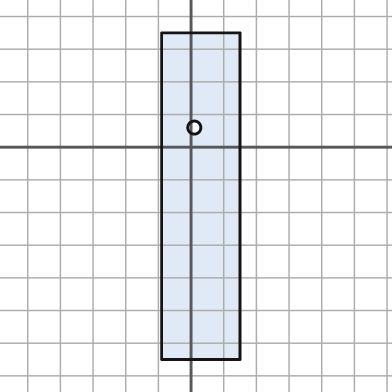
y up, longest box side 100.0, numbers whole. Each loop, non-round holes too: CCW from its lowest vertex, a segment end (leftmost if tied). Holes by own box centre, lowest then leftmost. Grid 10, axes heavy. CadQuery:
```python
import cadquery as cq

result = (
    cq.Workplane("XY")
    .moveTo(-9.0, -65.0)
    .lineTo(15.0, -65.0)
    .lineTo(15.0, 35.0)
    .lineTo(-9.0, 35.0)
    .close()
    .moveTo(1.0, 6.0)
    .circle(2.0)
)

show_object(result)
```